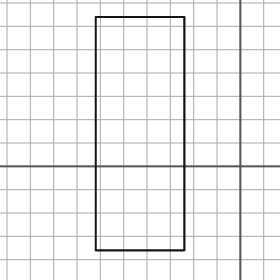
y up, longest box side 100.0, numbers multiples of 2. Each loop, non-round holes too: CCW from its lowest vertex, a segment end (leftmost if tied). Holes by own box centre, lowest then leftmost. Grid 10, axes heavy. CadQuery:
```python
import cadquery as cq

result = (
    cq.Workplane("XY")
    .moveTo(-62.0, -36.0)
    .lineTo(-24.0, -36.0)
    .lineTo(-24.0, 64.0)
    .lineTo(-62.0, 64.0)
    .close()
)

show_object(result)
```